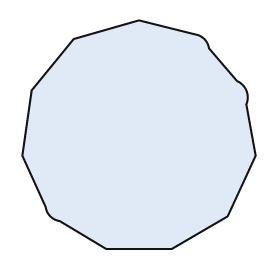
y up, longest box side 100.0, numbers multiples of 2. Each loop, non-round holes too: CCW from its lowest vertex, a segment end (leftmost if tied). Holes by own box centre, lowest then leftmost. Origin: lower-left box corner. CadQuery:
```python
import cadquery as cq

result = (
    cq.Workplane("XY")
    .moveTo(36.0, 0.0)
    .lineTo(64.0, 0.0)
    .lineTo(88.0, 14.0)
    .lineTo(100.0, 40.0)
    .lineTo(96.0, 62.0)
    .threePointArc((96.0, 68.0), (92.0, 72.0))
    .lineTo(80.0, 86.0)
    .threePointArc((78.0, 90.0), (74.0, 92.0))
    .lineTo(50.0, 98.0)
    .lineTo(22.0, 90.0)
    .lineTo(4.0, 68.0)
    .lineTo(0.0, 40.0)
    .lineTo(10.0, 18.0)
    .threePointArc((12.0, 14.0), (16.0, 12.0))
    .close()
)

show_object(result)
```